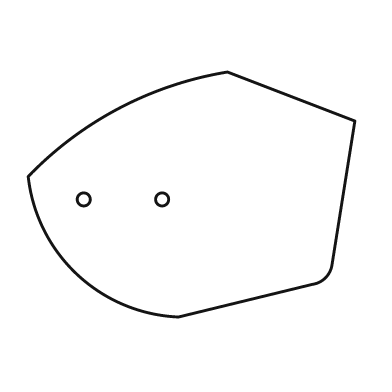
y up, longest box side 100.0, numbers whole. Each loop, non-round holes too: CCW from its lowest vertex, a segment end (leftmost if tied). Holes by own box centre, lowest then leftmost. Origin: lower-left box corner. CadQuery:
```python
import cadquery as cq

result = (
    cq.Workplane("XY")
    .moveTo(46.0, 0.0)
    .lineTo(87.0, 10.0)
    .threePointArc((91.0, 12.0), (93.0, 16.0))
    .lineTo(100.0, 60.0)
    .lineTo(61.0, 75.0)
    .threePointArc((28.0, 64.0), (0.0, 43.0))
    .threePointArc((15.0, 13.0), (46.0, 0.0))
    .close()
    .moveTo(17.0, 36.0)
    .circle(2.0)
    .moveTo(41.0, 36.0)
    .circle(2.0)
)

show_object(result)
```